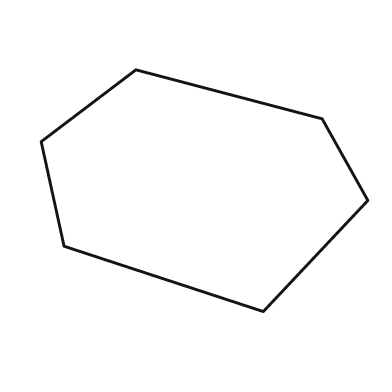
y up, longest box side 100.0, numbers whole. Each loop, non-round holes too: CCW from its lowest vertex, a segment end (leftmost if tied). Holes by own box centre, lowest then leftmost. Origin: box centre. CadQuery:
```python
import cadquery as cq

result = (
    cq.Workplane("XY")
    .moveTo(18.0, -37.0)
    .lineTo(50.0, -3.0)
    .lineTo(36.0, 22.0)
    .lineTo(-21.0, 37.0)
    .lineTo(-50.0, 15.0)
    .lineTo(-43.0, -17.0)
    .close()
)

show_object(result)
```